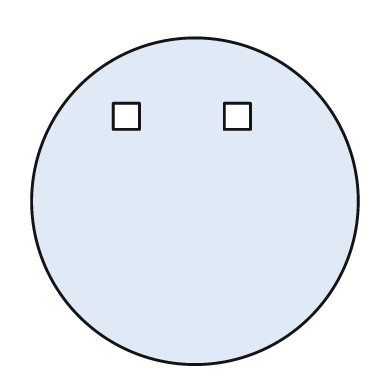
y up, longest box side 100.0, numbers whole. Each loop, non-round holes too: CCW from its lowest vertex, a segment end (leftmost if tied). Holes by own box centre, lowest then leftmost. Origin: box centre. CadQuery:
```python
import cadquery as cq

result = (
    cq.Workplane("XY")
    .moveTo(0.0, 0.0)
    .circle(50.0)
    .moveTo(-25.0, 22.0)
    .lineTo(-17.0, 22.0)
    .lineTo(-17.0, 30.0)
    .lineTo(-25.0, 30.0)
    .close()
    .moveTo(9.0, 22.0)
    .lineTo(17.0, 22.0)
    .lineTo(17.0, 30.0)
    .lineTo(9.0, 30.0)
    .close()
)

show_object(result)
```